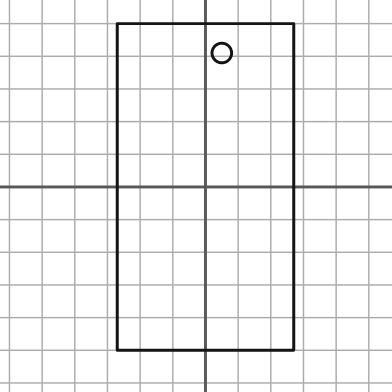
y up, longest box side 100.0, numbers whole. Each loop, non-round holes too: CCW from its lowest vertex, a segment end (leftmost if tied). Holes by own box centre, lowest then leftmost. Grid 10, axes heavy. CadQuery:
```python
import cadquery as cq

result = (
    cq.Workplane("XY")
    .moveTo(-27.0, -50.0)
    .lineTo(27.0, -50.0)
    .lineTo(27.0, 50.0)
    .lineTo(-27.0, 50.0)
    .close()
    .moveTo(5.0, 41.0)
    .circle(3.0)
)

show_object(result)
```